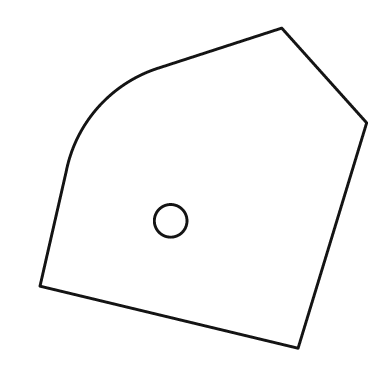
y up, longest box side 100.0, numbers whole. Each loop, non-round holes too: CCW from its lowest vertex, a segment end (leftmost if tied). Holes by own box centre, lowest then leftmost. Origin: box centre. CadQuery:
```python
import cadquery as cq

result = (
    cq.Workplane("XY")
    .moveTo(29.0, -49.0)
    .lineTo(50.0, 20.0)
    .lineTo(24.0, 49.0)
    .lineTo(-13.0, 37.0)
    .threePointArc((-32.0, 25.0), (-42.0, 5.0))
    .lineTo(-50.0, -30.0)
    .close()
    .moveTo(-10.0, -10.0)
    .circle(5.0)
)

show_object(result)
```